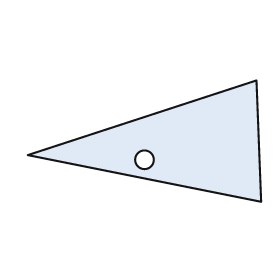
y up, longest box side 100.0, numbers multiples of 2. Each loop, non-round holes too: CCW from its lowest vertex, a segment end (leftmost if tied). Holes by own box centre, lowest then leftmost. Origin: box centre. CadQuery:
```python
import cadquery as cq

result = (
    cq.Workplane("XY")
    .moveTo(50.0, -26.0)
    .lineTo(48.0, 26.0)
    .lineTo(-50.0, -6.0)
    .close()
    .moveTo(0.0, -8.0)
    .circle(4.0)
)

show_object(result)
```